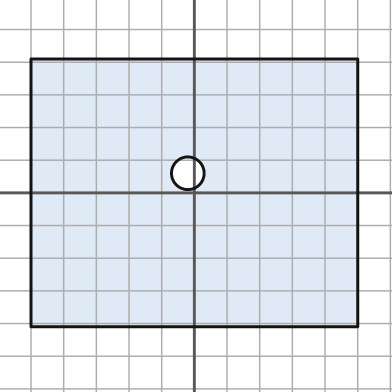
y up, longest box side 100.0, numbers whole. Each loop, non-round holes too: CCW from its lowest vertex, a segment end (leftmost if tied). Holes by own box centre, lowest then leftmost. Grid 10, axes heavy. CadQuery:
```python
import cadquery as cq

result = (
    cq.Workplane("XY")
    .moveTo(-50.0, -41.0)
    .lineTo(50.0, -41.0)
    .lineTo(50.0, 41.0)
    .lineTo(-50.0, 41.0)
    .close()
    .moveTo(-2.0, 6.0)
    .circle(5.0)
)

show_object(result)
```